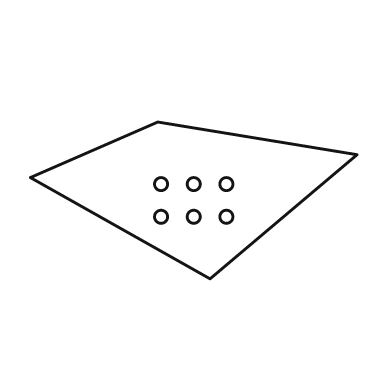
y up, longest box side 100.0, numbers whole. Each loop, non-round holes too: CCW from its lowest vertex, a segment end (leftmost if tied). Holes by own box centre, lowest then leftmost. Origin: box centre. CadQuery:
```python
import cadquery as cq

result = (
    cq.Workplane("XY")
    .moveTo(5.0, -24.0)
    .lineTo(50.0, 14.0)
    .lineTo(-11.0, 24.0)
    .lineTo(-50.0, 7.0)
    .close()
    .moveTo(-10.0, -5.0)
    .circle(2.0)
    .moveTo(0.0, -5.0)
    .circle(2.0)
    .moveTo(10.0, -5.0)
    .circle(2.0)
    .moveTo(-10.0, 5.0)
    .circle(2.0)
    .moveTo(0.0, 5.0)
    .circle(2.0)
    .moveTo(10.0, 5.0)
    .circle(2.0)
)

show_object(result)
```